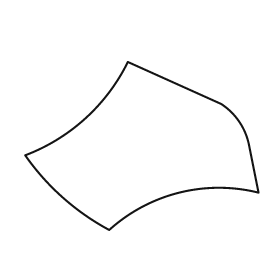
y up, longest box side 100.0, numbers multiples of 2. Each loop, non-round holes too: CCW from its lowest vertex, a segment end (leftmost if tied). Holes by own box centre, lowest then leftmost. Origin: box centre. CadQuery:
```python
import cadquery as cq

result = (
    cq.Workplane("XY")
    .moveTo(-14.0, -36.0)
    .threePointArc((16.0, -20.0), (50.0, -20.0))
    .lineTo(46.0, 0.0)
    .threePointArc((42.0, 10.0), (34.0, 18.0))
    .lineTo(-6.0, 36.0)
    .threePointArc((-24.0, 12.0), (-50.0, -4.0))
    .threePointArc((-34.0, -22.0), (-14.0, -36.0))
    .close()
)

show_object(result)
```